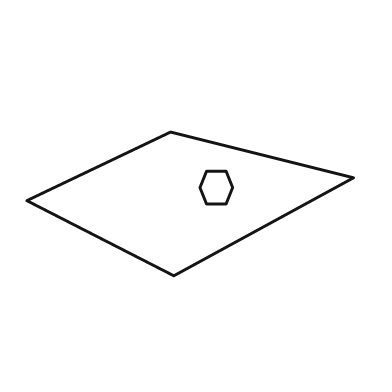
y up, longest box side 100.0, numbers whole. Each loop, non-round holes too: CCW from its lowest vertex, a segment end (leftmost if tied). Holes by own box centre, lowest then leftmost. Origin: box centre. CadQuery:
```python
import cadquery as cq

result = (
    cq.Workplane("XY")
    .moveTo(-5.0, -22.0)
    .lineTo(50.0, 8.0)
    .lineTo(-6.0, 22.0)
    .lineTo(-50.0, 1.0)
    .close()
    .moveTo(5.0, 0.0)
    .lineTo(11.0, 0.0)
    .lineTo(13.0, 5.0)
    .lineTo(11.0, 10.0)
    .lineTo(5.0, 10.0)
    .lineTo(3.0, 5.0)
    .close()
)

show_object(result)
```